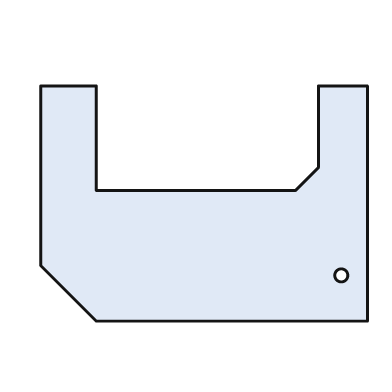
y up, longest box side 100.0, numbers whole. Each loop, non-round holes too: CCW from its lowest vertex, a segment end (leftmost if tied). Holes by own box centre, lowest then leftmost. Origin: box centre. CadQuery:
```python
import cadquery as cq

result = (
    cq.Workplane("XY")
    .moveTo(-33.0, -36.0)
    .lineTo(50.0, -36.0)
    .lineTo(50.0, 36.0)
    .lineTo(35.0, 36.0)
    .lineTo(35.0, 11.0)
    .lineTo(28.0, 4.0)
    .lineTo(-33.0, 4.0)
    .lineTo(-33.0, 36.0)
    .lineTo(-50.0, 36.0)
    .lineTo(-50.0, -19.0)
    .close()
    .moveTo(42.0, -22.0)
    .circle(2.0)
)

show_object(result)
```